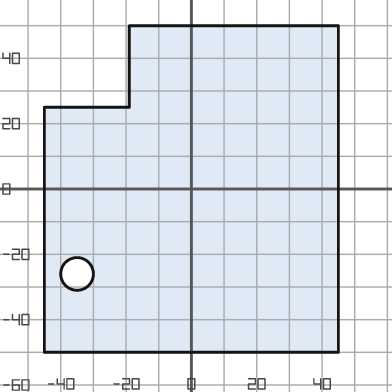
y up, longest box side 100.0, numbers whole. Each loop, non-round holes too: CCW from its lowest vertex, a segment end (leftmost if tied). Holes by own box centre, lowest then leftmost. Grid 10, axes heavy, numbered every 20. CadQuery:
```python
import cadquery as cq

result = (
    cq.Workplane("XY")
    .moveTo(-45.0, -50.0)
    .lineTo(45.0, -50.0)
    .lineTo(45.0, 50.0)
    .lineTo(-19.0, 50.0)
    .lineTo(-19.0, 25.0)
    .lineTo(-45.0, 25.0)
    .close()
    .moveTo(-35.0, -26.0)
    .circle(5.0)
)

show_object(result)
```